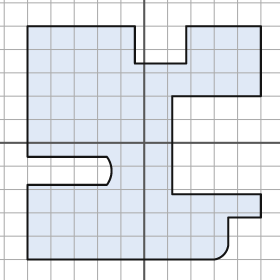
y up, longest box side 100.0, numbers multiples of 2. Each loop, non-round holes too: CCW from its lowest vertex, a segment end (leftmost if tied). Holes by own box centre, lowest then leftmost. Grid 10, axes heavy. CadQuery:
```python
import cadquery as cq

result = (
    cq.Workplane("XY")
    .moveTo(-50.0, -50.0)
    .lineTo(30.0, -50.0)
    .threePointArc((34.0, -48.0), (36.0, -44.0))
    .lineTo(36.0, -32.0)
    .lineTo(50.0, -32.0)
    .lineTo(50.0, -22.0)
    .lineTo(12.0, -22.0)
    .lineTo(12.0, 20.0)
    .lineTo(50.0, 20.0)
    .lineTo(50.0, 50.0)
    .lineTo(18.0, 50.0)
    .lineTo(18.0, 34.0)
    .lineTo(-4.0, 34.0)
    .lineTo(-4.0, 50.0)
    .lineTo(-50.0, 50.0)
    .lineTo(-50.0, -6.0)
    .lineTo(-16.0, -6.0)
    .threePointArc((-14.0, -12.0), (-16.0, -18.0))
    .lineTo(-50.0, -18.0)
    .close()
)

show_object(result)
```